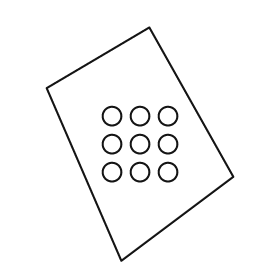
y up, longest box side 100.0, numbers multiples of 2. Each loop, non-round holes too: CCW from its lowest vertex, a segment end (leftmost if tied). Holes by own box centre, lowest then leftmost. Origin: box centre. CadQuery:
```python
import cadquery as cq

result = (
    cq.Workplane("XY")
    .moveTo(-8.0, -50.0)
    .lineTo(40.0, -14.0)
    .lineTo(4.0, 50.0)
    .lineTo(-40.0, 24.0)
    .close()
    .moveTo(-12.0, -12.0)
    .circle(4.0)
    .moveTo(0.0, -12.0)
    .circle(4.0)
    .moveTo(12.0, -12.0)
    .circle(4.0)
    .moveTo(-12.0, 0.0)
    .circle(4.0)
    .moveTo(0.0, 0.0)
    .circle(4.0)
    .moveTo(12.0, 0.0)
    .circle(4.0)
    .moveTo(-12.0, 12.0)
    .circle(4.0)
    .moveTo(0.0, 12.0)
    .circle(4.0)
    .moveTo(12.0, 12.0)
    .circle(4.0)
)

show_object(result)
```